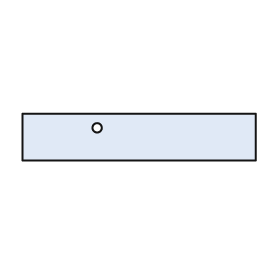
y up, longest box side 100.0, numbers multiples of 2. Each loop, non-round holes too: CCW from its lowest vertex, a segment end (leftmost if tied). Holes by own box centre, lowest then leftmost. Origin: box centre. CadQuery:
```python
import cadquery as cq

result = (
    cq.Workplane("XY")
    .moveTo(-50.0, -10.0)
    .lineTo(50.0, -10.0)
    .lineTo(50.0, 10.0)
    .lineTo(-50.0, 10.0)
    .close()
    .moveTo(-18.0, 4.0)
    .circle(2.0)
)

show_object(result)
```